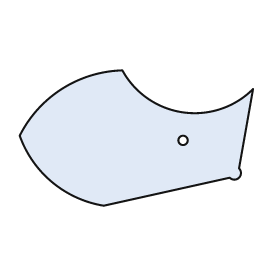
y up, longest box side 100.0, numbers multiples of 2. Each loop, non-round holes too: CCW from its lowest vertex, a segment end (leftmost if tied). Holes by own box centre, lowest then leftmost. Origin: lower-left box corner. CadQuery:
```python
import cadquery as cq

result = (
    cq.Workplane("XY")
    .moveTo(36.0, 0.0)
    .lineTo(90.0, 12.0)
    .threePointArc((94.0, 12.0), (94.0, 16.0))
    .lineTo(100.0, 50.0)
    .threePointArc((70.0, 40.0), (44.0, 58.0))
    .threePointArc((18.0, 50.0), (0.0, 30.0))
    .threePointArc((14.0, 10.0), (36.0, 0.0))
    .close()
    .moveTo(70.0, 28.0)
    .circle(2.0)
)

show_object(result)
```